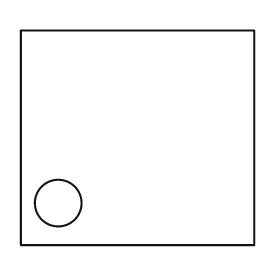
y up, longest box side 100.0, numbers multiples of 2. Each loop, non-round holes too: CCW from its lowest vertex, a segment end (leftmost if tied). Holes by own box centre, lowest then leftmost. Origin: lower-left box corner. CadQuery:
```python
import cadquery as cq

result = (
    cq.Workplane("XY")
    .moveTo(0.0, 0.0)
    .lineTo(100.0, 0.0)
    .lineTo(100.0, 92.0)
    .lineTo(0.0, 92.0)
    .close()
    .moveTo(16.0, 18.0)
    .circle(10.0)
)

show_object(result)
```